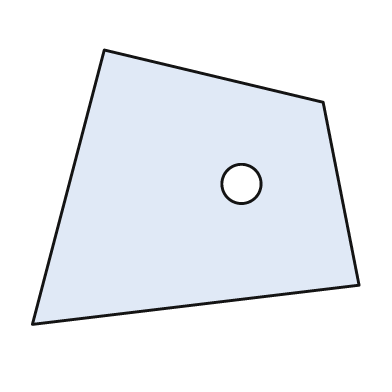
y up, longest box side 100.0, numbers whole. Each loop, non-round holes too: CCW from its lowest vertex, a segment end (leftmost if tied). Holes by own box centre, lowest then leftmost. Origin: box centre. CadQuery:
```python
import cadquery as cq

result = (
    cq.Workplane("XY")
    .moveTo(-50.0, -42.0)
    .lineTo(50.0, -30.0)
    .lineTo(39.0, 26.0)
    .lineTo(-28.0, 42.0)
    .close()
    .moveTo(14.0, 1.0)
    .circle(6.0)
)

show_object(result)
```